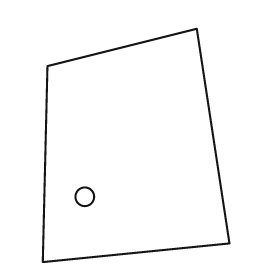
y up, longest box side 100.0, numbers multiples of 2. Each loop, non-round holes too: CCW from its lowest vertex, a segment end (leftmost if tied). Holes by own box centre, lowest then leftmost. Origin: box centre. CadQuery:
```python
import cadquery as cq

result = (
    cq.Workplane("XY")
    .moveTo(-40.0, -50.0)
    .lineTo(40.0, -42.0)
    .lineTo(26.0, 50.0)
    .lineTo(-38.0, 34.0)
    .close()
    .moveTo(-22.0, -22.0)
    .circle(4.0)
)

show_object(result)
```